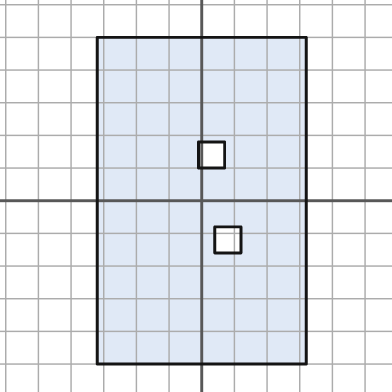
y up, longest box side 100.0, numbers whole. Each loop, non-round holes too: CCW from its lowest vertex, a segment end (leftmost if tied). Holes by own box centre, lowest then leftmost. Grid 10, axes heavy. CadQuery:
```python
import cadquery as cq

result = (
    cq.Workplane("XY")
    .moveTo(-32.0, -50.0)
    .lineTo(32.0, -50.0)
    .lineTo(32.0, 50.0)
    .lineTo(-32.0, 50.0)
    .close()
    .moveTo(4.0, -16.0)
    .lineTo(12.0, -16.0)
    .lineTo(12.0, -8.0)
    .lineTo(4.0, -8.0)
    .close()
    .moveTo(-1.0, 10.0)
    .lineTo(7.0, 10.0)
    .lineTo(7.0, 18.0)
    .lineTo(-1.0, 18.0)
    .close()
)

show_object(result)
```